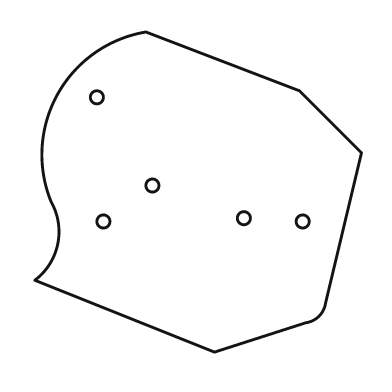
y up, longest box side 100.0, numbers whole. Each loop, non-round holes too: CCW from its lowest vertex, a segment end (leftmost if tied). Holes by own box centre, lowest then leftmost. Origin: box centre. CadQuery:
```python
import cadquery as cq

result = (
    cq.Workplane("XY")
    .moveTo(5.0, -49.0)
    .lineTo(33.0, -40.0)
    .threePointArc((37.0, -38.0), (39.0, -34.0))
    .lineTo(50.0, 12.0)
    .lineTo(31.0, 31.0)
    .lineTo(-16.0, 49.0)
    .threePointArc((-43.0, 30.0), (-45.0, -3.0))
    .threePointArc((-43.0, -16.0), (-50.0, -27.0))
    .close()
    .moveTo(-29.0, -9.0)
    .circle(2.0)
    .moveTo(32.0, -9.0)
    .circle(2.0)
    .moveTo(14.0, -8.0)
    .circle(2.0)
    .moveTo(-14.0, 2.0)
    .circle(2.0)
    .moveTo(-31.0, 29.0)
    .circle(2.0)
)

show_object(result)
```